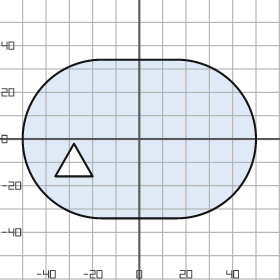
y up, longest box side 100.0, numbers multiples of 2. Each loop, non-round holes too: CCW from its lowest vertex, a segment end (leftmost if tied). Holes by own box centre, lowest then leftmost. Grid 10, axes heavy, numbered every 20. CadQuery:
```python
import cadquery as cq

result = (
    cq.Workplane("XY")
    .moveTo(-16.0, -34.0)
    .lineTo(16.0, -34.0)
    .threePointArc((50.0, 0.0), (16.0, 34.0))
    .lineTo(-16.0, 34.0)
    .threePointArc((-50.0, 0.0), (-16.0, -34.0))
    .close()
    .moveTo(-36.0, -16.0)
    .lineTo(-20.0, -16.0)
    .lineTo(-28.0, -2.0)
    .close()
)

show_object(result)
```